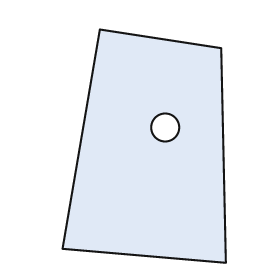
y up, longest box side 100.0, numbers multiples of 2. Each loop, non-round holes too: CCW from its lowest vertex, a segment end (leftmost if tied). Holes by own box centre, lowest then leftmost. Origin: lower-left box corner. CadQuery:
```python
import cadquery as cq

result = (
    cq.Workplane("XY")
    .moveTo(70.0, 0.0)
    .lineTo(68.0, 92.0)
    .lineTo(16.0, 100.0)
    .lineTo(0.0, 6.0)
    .close()
    .moveTo(44.0, 58.0)
    .circle(6.0)
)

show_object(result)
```